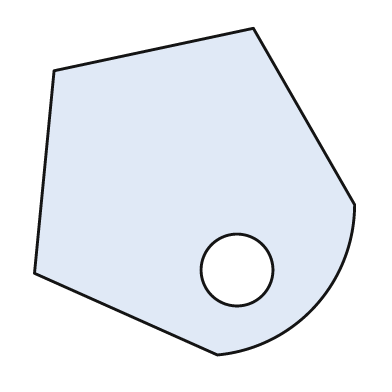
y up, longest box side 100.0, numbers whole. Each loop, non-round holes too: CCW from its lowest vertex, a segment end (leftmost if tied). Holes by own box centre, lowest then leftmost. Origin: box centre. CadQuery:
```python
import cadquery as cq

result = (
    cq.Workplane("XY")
    .moveTo(7.0, -50.0)
    .threePointArc((37.0, -35.0), (49.0, -4.0))
    .lineTo(18.0, 50.0)
    .lineTo(-43.0, 37.0)
    .lineTo(-49.0, -25.0)
    .close()
    .moveTo(13.0, -24.0)
    .circle(11.0)
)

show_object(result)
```